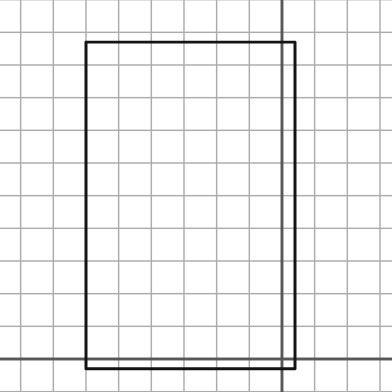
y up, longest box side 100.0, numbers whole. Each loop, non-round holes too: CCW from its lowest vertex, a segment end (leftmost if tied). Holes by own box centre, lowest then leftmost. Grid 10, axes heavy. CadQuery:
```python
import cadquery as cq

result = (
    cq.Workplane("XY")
    .moveTo(-60.0, -3.0)
    .lineTo(4.0, -3.0)
    .lineTo(4.0, 97.0)
    .lineTo(-60.0, 97.0)
    .close()
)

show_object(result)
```